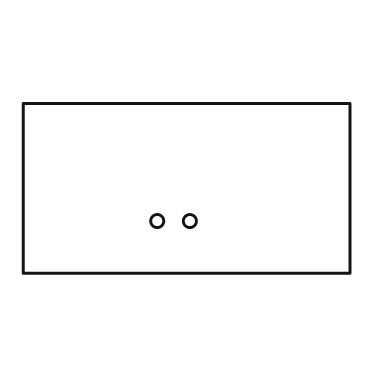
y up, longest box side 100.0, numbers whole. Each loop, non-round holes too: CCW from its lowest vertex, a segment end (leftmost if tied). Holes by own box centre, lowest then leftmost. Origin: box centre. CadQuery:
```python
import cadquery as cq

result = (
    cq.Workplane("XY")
    .moveTo(-50.0, -26.0)
    .lineTo(50.0, -26.0)
    .lineTo(50.0, 26.0)
    .lineTo(-50.0, 26.0)
    .close()
    .moveTo(-9.0, -10.0)
    .circle(2.0)
    .moveTo(1.0, -10.0)
    .circle(2.0)
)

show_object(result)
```